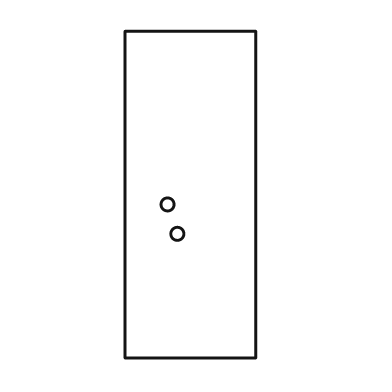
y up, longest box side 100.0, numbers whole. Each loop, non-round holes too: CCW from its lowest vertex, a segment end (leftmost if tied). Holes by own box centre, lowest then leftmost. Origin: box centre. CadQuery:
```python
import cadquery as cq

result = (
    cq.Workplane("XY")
    .moveTo(-20.0, -50.0)
    .lineTo(20.0, -50.0)
    .lineTo(20.0, 50.0)
    .lineTo(-20.0, 50.0)
    .close()
    .moveTo(-4.0, -12.0)
    .circle(2.0)
    .moveTo(-7.0, -3.0)
    .circle(2.0)
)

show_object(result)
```